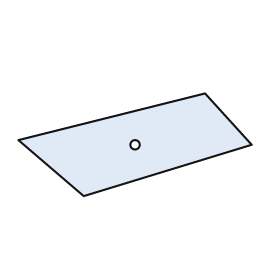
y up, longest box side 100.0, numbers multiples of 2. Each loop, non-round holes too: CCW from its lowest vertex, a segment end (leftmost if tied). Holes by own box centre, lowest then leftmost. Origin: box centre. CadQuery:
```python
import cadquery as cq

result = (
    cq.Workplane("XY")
    .moveTo(-22.0, -22.0)
    .lineTo(50.0, 0.0)
    .lineTo(30.0, 22.0)
    .lineTo(-50.0, 2.0)
    .close()
    .moveTo(0.0, 0.0)
    .circle(2.0)
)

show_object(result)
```